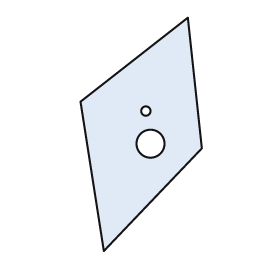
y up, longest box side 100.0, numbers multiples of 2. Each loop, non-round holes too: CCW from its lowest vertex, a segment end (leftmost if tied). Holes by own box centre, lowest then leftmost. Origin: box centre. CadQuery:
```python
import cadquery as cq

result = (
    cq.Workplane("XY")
    .moveTo(-16.0, -50.0)
    .lineTo(26.0, -6.0)
    .lineTo(20.0, 50.0)
    .lineTo(-26.0, 14.0)
    .close()
    .moveTo(4.0, -4.0)
    .circle(6.0)
    .moveTo(2.0, 10.0)
    .circle(2.0)
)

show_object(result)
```